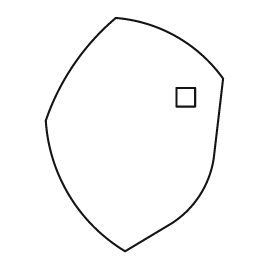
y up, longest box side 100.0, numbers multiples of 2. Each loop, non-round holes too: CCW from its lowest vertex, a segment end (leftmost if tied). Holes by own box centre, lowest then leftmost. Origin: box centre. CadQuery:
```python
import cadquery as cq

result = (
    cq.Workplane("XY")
    .moveTo(-4.0, -50.0)
    .lineTo(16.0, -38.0)
    .threePointArc((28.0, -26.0), (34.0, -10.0))
    .lineTo(38.0, 24.0)
    .threePointArc((18.0, 42.0), (-8.0, 50.0))
    .threePointArc((-26.0, 30.0), (-38.0, 6.0))
    .threePointArc((-28.0, -26.0), (-4.0, -50.0))
    .close()
    .moveTo(18.0, 12.0)
    .lineTo(26.0, 12.0)
    .lineTo(26.0, 20.0)
    .lineTo(18.0, 20.0)
    .close()
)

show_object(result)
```